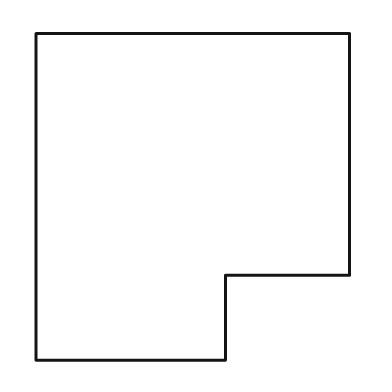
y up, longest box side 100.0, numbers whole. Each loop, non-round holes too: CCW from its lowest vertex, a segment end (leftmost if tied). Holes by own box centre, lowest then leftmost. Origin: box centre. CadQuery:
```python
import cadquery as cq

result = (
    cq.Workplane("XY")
    .moveTo(-48.0, -50.0)
    .lineTo(10.0, -50.0)
    .lineTo(10.0, -24.0)
    .lineTo(48.0, -24.0)
    .lineTo(48.0, 50.0)
    .lineTo(-48.0, 50.0)
    .close()
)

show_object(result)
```